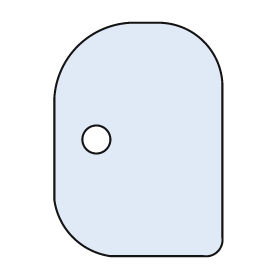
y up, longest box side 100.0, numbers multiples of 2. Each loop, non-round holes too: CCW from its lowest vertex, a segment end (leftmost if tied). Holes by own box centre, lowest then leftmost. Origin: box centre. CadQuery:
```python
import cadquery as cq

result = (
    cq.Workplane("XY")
    .moveTo(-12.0, -50.0)
    .lineTo(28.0, -50.0)
    .threePointArc((34.0, -48.0), (36.0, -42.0))
    .lineTo(36.0, 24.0)
    .threePointArc((28.0, 42.0), (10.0, 50.0))
    .lineTo(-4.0, 50.0)
    .threePointArc((-26.0, 40.0), (-36.0, 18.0))
    .lineTo(-36.0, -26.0)
    .threePointArc((-28.0, -42.0), (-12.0, -50.0))
    .close()
    .moveTo(-18.0, 0.0)
    .circle(6.0)
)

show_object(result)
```